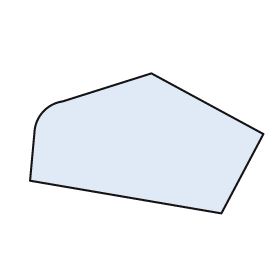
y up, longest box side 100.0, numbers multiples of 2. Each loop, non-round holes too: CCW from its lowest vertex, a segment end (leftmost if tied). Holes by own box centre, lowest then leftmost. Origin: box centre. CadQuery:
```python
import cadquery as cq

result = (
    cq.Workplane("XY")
    .moveTo(32.0, -30.0)
    .lineTo(50.0, 4.0)
    .lineTo(2.0, 30.0)
    .lineTo(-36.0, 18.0)
    .threePointArc((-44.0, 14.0), (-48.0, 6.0))
    .lineTo(-50.0, -16.0)
    .close()
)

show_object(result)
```